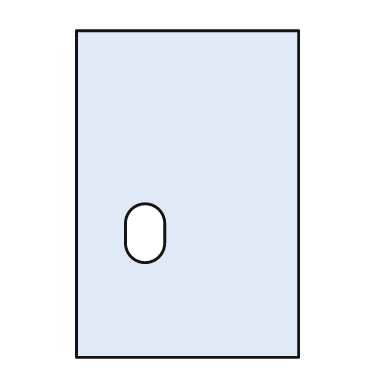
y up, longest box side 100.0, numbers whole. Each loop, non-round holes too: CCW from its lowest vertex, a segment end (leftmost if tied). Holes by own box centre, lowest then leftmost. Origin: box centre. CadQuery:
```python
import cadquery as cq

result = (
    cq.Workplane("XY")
    .moveTo(-34.0, -50.0)
    .lineTo(34.0, -50.0)
    .lineTo(34.0, 50.0)
    .lineTo(-34.0, 50.0)
    .close()
    .moveTo(-19.0, -15.0)
    .threePointArc((-13.0, -21.0), (-7.0, -15.0))
    .lineTo(-7.0, -9.0)
    .threePointArc((-13.0, -3.0), (-19.0, -9.0))
    .close()
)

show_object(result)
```